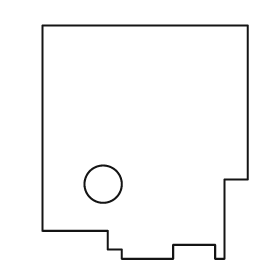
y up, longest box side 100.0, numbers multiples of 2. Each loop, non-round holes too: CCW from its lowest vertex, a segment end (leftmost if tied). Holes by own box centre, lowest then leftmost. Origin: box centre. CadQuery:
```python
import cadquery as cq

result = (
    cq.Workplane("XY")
    .moveTo(-10.0, -50.0)
    .lineTo(12.0, -50.0)
    .lineTo(12.0, -44.0)
    .lineTo(30.0, -44.0)
    .lineTo(30.0, -50.0)
    .lineTo(34.0, -50.0)
    .lineTo(34.0, -16.0)
    .lineTo(44.0, -16.0)
    .lineTo(44.0, 50.0)
    .lineTo(-44.0, 50.0)
    .lineTo(-44.0, -38.0)
    .lineTo(-16.0, -38.0)
    .lineTo(-16.0, -46.0)
    .lineTo(-10.0, -46.0)
    .close()
    .moveTo(-18.0, -18.0)
    .circle(8.0)
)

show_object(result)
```